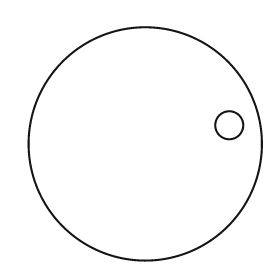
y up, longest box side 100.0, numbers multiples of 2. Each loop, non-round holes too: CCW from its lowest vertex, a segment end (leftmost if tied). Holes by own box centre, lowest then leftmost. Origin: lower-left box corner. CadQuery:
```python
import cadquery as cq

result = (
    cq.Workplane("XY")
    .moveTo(50.0, 50.0)
    .circle(50.0)
    .moveTo(86.0, 58.0)
    .circle(6.0)
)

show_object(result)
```